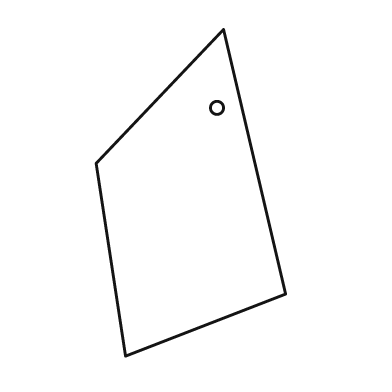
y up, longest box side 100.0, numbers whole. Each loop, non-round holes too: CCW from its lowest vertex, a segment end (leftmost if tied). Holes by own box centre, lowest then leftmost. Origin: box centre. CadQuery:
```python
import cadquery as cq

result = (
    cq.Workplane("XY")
    .moveTo(-20.0, -50.0)
    .lineTo(29.0, -31.0)
    .lineTo(10.0, 50.0)
    .lineTo(-29.0, 9.0)
    .close()
    .moveTo(8.0, 26.0)
    .circle(2.0)
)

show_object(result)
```